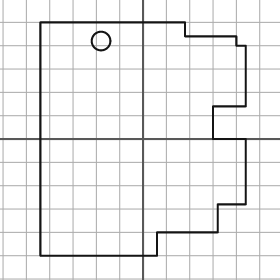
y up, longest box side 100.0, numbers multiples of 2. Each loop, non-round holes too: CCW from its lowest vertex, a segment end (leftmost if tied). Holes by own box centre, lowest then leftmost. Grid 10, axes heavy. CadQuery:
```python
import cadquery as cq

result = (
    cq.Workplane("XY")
    .moveTo(-44.0, -50.0)
    .lineTo(6.0, -50.0)
    .lineTo(6.0, -40.0)
    .lineTo(32.0, -40.0)
    .lineTo(32.0, -28.0)
    .lineTo(44.0, -28.0)
    .lineTo(44.0, 0.0)
    .lineTo(30.0, 0.0)
    .lineTo(30.0, 14.0)
    .lineTo(44.0, 14.0)
    .lineTo(44.0, 40.0)
    .lineTo(40.0, 40.0)
    .lineTo(40.0, 44.0)
    .lineTo(18.0, 44.0)
    .lineTo(18.0, 50.0)
    .lineTo(-44.0, 50.0)
    .close()
    .moveTo(-18.0, 42.0)
    .circle(4.0)
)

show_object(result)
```